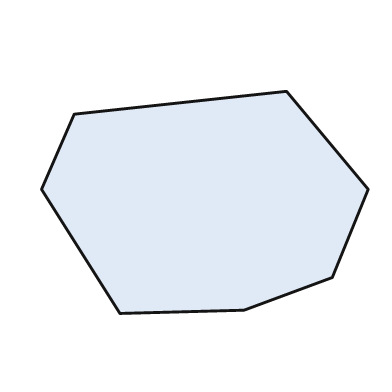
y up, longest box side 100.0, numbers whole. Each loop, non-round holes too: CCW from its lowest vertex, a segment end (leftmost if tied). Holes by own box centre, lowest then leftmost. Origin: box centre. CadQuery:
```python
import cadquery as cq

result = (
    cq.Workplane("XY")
    .moveTo(-26.0, -34.0)
    .lineTo(12.0, -33.0)
    .lineTo(39.0, -23.0)
    .lineTo(50.0, 4.0)
    .lineTo(25.0, 34.0)
    .lineTo(-40.0, 27.0)
    .lineTo(-50.0, 4.0)
    .close()
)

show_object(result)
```